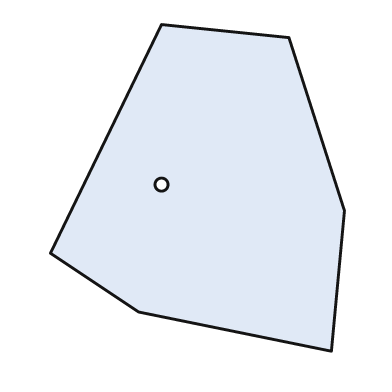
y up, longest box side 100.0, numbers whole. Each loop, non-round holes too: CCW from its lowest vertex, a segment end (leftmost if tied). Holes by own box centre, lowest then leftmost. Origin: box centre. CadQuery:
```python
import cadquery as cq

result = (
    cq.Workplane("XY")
    .moveTo(41.0, -50.0)
    .lineTo(45.0, -7.0)
    .lineTo(28.0, 46.0)
    .lineTo(-11.0, 50.0)
    .lineTo(-45.0, -20.0)
    .lineTo(-18.0, -38.0)
    .close()
    .moveTo(-11.0, 1.0)
    .circle(2.0)
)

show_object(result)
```